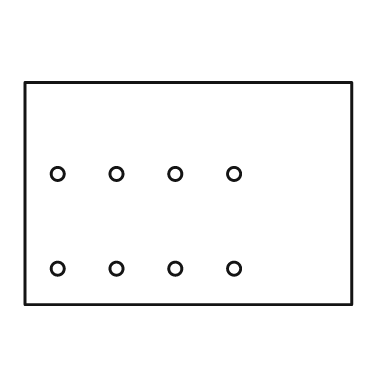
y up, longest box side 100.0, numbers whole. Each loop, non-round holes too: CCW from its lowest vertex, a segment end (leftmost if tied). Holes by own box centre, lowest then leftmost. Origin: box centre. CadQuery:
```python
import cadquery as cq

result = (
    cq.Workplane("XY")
    .moveTo(-50.0, -34.0)
    .lineTo(50.0, -34.0)
    .lineTo(50.0, 34.0)
    .lineTo(-50.0, 34.0)
    .close()
    .moveTo(-40.0, -23.0)
    .circle(2.0)
    .moveTo(-22.0, -23.0)
    .circle(2.0)
    .moveTo(-4.0, -23.0)
    .circle(2.0)
    .moveTo(14.0, -23.0)
    .circle(2.0)
    .moveTo(-40.0, 6.0)
    .circle(2.0)
    .moveTo(-22.0, 6.0)
    .circle(2.0)
    .moveTo(-4.0, 6.0)
    .circle(2.0)
    .moveTo(14.0, 6.0)
    .circle(2.0)
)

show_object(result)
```